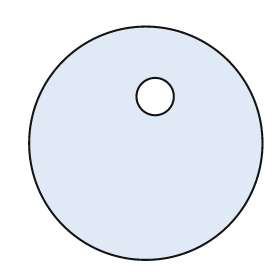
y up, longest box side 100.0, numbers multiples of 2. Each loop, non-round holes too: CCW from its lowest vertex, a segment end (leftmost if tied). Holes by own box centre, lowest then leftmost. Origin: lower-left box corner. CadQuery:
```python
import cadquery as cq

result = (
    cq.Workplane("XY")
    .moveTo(50.0, 50.0)
    .circle(50.0)
    .moveTo(54.0, 70.0)
    .circle(8.0)
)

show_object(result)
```